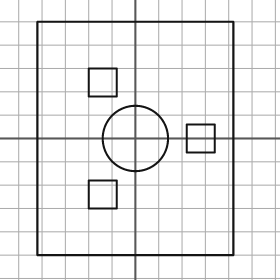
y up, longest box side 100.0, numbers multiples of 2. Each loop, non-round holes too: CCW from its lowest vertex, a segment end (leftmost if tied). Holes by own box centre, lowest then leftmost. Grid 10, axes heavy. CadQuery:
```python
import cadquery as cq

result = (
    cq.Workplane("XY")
    .moveTo(-42.0, -50.0)
    .lineTo(42.0, -50.0)
    .lineTo(42.0, 50.0)
    .lineTo(-42.0, 50.0)
    .close()
    .moveTo(-20.0, -30.0)
    .lineTo(-8.0, -30.0)
    .lineTo(-8.0, -18.0)
    .lineTo(-20.0, -18.0)
    .close()
    .moveTo(0.0, 0.0)
    .circle(14.0)
    .moveTo(22.0, -6.0)
    .lineTo(34.0, -6.0)
    .lineTo(34.0, 6.0)
    .lineTo(22.0, 6.0)
    .close()
    .moveTo(-20.0, 18.0)
    .lineTo(-8.0, 18.0)
    .lineTo(-8.0, 30.0)
    .lineTo(-20.0, 30.0)
    .close()
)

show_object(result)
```